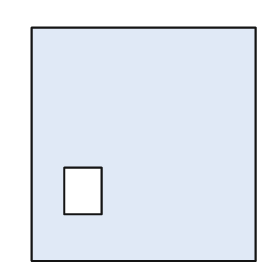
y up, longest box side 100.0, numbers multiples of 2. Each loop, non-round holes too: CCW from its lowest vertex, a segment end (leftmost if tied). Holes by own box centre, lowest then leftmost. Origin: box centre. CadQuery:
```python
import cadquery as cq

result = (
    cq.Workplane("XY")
    .moveTo(-48.0, -50.0)
    .lineTo(48.0, -50.0)
    .lineTo(48.0, 50.0)
    .lineTo(-48.0, 50.0)
    .close()
    .moveTo(-34.0, -30.0)
    .lineTo(-18.0, -30.0)
    .lineTo(-18.0, -10.0)
    .lineTo(-34.0, -10.0)
    .close()
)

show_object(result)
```